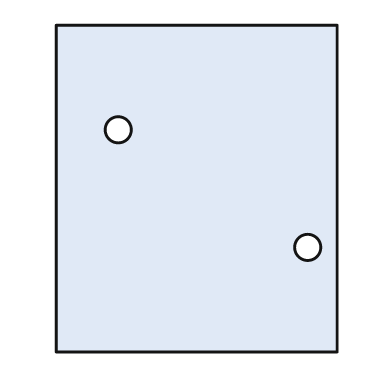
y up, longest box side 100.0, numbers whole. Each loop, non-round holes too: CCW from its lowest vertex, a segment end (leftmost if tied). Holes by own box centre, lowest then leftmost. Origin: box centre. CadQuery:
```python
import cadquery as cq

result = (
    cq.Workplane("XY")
    .moveTo(-43.0, -50.0)
    .lineTo(43.0, -50.0)
    .lineTo(43.0, 50.0)
    .lineTo(-43.0, 50.0)
    .close()
    .moveTo(34.0, -18.0)
    .circle(4.0)
    .moveTo(-24.0, 18.0)
    .circle(4.0)
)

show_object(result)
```